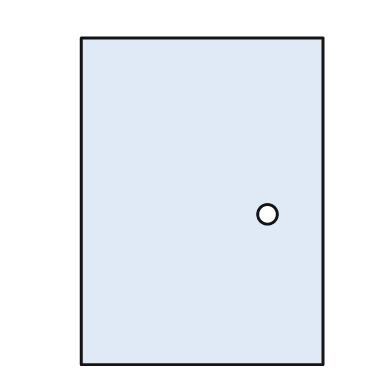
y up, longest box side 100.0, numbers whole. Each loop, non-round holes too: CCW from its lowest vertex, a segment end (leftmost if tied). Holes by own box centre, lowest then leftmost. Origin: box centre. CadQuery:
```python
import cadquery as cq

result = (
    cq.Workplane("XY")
    .moveTo(-37.0, -50.0)
    .lineTo(37.0, -50.0)
    .lineTo(37.0, 50.0)
    .lineTo(-37.0, 50.0)
    .close()
    .moveTo(20.0, -4.0)
    .circle(3.0)
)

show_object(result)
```